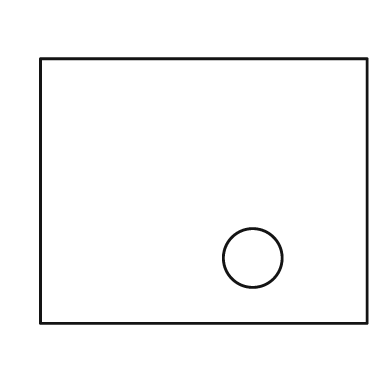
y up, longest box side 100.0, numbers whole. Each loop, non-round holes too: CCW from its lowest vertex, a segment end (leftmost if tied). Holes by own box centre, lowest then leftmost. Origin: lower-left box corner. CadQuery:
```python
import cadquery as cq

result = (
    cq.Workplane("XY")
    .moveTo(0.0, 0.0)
    .lineTo(100.0, 0.0)
    .lineTo(100.0, 81.0)
    .lineTo(0.0, 81.0)
    .close()
    .moveTo(65.0, 20.0)
    .circle(9.0)
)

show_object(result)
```